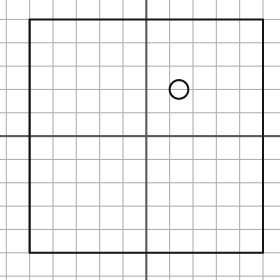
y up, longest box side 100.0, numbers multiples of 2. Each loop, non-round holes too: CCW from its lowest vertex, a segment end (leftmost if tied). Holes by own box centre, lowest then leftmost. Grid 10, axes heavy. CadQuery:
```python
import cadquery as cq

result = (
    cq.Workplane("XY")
    .moveTo(-50.0, -50.0)
    .lineTo(50.0, -50.0)
    .lineTo(50.0, 50.0)
    .lineTo(-50.0, 50.0)
    .close()
    .moveTo(14.0, 20.0)
    .circle(4.0)
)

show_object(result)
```